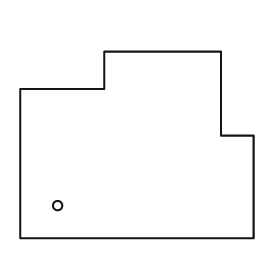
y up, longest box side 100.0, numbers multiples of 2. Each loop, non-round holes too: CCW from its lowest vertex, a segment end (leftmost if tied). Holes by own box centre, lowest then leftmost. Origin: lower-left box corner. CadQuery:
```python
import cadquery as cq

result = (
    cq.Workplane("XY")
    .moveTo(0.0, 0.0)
    .lineTo(100.0, 0.0)
    .lineTo(100.0, 44.0)
    .lineTo(86.0, 44.0)
    .lineTo(86.0, 80.0)
    .lineTo(36.0, 80.0)
    .lineTo(36.0, 64.0)
    .lineTo(0.0, 64.0)
    .close()
    .moveTo(16.0, 14.0)
    .circle(2.0)
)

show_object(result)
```